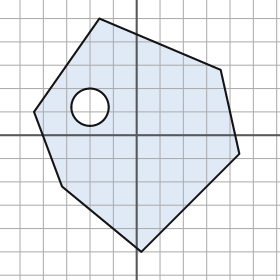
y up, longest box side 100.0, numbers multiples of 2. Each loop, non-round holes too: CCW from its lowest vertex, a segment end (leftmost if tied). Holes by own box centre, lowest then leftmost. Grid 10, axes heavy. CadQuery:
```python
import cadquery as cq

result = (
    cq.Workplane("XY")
    .moveTo(2.0, -50.0)
    .lineTo(44.0, -8.0)
    .lineTo(36.0, 28.0)
    .lineTo(-16.0, 50.0)
    .lineTo(-44.0, 10.0)
    .lineTo(-32.0, -22.0)
    .close()
    .moveTo(-20.0, 12.0)
    .circle(8.0)
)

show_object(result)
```